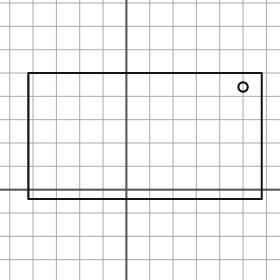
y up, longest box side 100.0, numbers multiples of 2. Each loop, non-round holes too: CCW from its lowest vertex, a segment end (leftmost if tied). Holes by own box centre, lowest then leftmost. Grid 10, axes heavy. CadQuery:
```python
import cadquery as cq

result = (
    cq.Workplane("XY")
    .moveTo(-42.0, -4.0)
    .lineTo(58.0, -4.0)
    .lineTo(58.0, 50.0)
    .lineTo(-42.0, 50.0)
    .close()
    .moveTo(50.0, 44.0)
    .circle(2.0)
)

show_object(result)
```